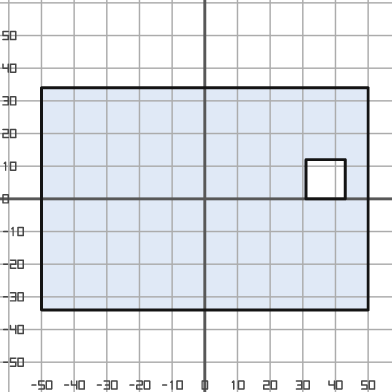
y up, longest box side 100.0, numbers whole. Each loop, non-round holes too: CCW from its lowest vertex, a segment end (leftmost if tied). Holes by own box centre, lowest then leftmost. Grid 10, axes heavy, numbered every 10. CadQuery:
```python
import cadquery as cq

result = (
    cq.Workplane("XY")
    .moveTo(-50.0, -34.0)
    .lineTo(50.0, -34.0)
    .lineTo(50.0, 34.0)
    .lineTo(-50.0, 34.0)
    .close()
    .moveTo(31.0, 0.0)
    .lineTo(43.0, 0.0)
    .lineTo(43.0, 12.0)
    .lineTo(31.0, 12.0)
    .close()
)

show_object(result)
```